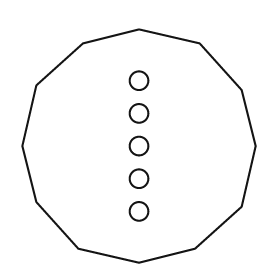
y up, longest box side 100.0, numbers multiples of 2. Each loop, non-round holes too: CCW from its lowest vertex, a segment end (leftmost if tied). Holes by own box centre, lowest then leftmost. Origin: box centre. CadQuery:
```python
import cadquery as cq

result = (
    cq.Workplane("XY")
    .moveTo(0.0, -50.0)
    .lineTo(24.0, -44.0)
    .lineTo(44.0, -26.0)
    .lineTo(50.0, 0.0)
    .lineTo(44.0, 24.0)
    .lineTo(26.0, 44.0)
    .lineTo(0.0, 50.0)
    .lineTo(-24.0, 44.0)
    .lineTo(-44.0, 26.0)
    .lineTo(-50.0, 0.0)
    .lineTo(-44.0, -24.0)
    .lineTo(-26.0, -44.0)
    .close()
    .moveTo(0.0, -28.0)
    .circle(4.0)
    .moveTo(0.0, -14.0)
    .circle(4.0)
    .moveTo(0.0, 0.0)
    .circle(4.0)
    .moveTo(0.0, 14.0)
    .circle(4.0)
    .moveTo(0.0, 28.0)
    .circle(4.0)
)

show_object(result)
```